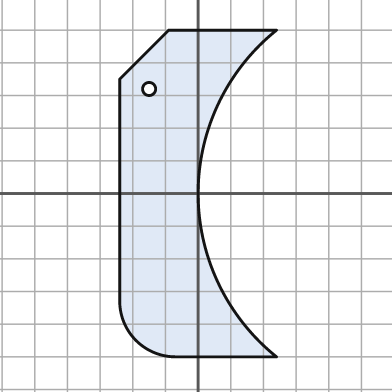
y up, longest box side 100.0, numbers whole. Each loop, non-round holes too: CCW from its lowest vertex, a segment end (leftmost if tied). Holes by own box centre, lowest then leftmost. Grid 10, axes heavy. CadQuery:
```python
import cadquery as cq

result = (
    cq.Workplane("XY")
    .moveTo(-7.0, -50.0)
    .lineTo(24.0, -50.0)
    .threePointArc((0.0, 0.0), (24.0, 50.0))
    .lineTo(-9.0, 50.0)
    .lineTo(-24.0, 35.0)
    .lineTo(-24.0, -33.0)
    .threePointArc((-19.0, -45.0), (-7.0, -50.0))
    .close()
    .moveTo(-15.0, 32.0)
    .circle(2.0)
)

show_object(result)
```